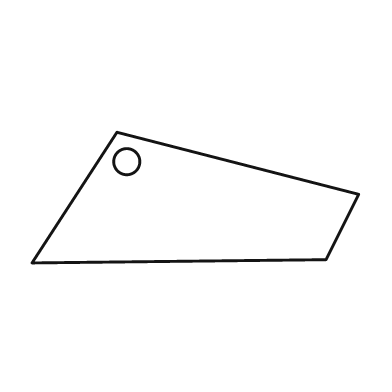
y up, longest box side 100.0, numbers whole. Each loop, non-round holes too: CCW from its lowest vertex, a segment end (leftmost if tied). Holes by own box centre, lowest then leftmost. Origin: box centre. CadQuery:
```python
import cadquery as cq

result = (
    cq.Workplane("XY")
    .moveTo(-50.0, -20.0)
    .lineTo(40.0, -19.0)
    .lineTo(50.0, 1.0)
    .lineTo(-24.0, 20.0)
    .close()
    .moveTo(-21.0, 11.0)
    .circle(4.0)
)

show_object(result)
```